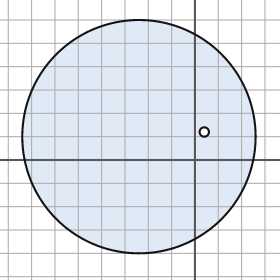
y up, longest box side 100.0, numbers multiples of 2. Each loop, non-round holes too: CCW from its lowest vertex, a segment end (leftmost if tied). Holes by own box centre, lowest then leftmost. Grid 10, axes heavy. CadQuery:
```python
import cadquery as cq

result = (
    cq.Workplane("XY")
    .moveTo(-24.0, 10.0)
    .circle(50.0)
    .moveTo(4.0, 12.0)
    .circle(2.0)
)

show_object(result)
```